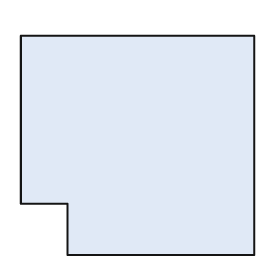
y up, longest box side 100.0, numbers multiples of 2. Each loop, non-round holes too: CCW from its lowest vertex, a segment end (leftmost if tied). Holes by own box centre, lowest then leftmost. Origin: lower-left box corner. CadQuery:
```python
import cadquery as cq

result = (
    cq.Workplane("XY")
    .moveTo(20.0, 0.0)
    .lineTo(100.0, 0.0)
    .lineTo(100.0, 94.0)
    .lineTo(0.0, 94.0)
    .lineTo(0.0, 22.0)
    .lineTo(20.0, 22.0)
    .close()
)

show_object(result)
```